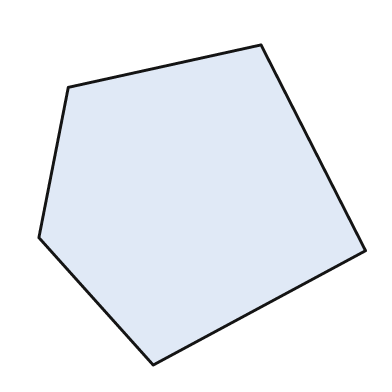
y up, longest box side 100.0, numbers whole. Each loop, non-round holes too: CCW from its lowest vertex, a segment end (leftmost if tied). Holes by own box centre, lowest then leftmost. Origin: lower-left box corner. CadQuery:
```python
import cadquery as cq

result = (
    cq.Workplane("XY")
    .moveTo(35.0, 0.0)
    .lineTo(100.0, 35.0)
    .lineTo(68.0, 98.0)
    .lineTo(9.0, 85.0)
    .lineTo(0.0, 39.0)
    .close()
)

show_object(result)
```